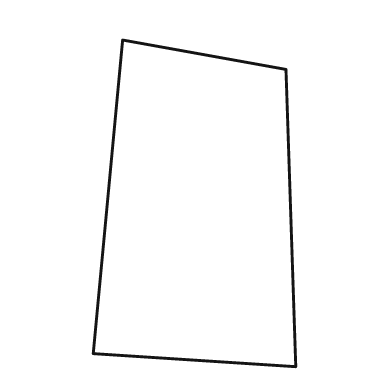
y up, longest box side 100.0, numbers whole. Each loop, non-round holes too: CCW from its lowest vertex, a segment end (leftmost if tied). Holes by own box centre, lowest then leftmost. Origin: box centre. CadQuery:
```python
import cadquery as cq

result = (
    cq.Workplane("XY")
    .moveTo(31.0, -50.0)
    .lineTo(28.0, 41.0)
    .lineTo(-22.0, 50.0)
    .lineTo(-31.0, -46.0)
    .close()
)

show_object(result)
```